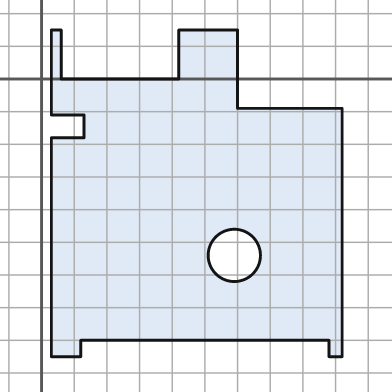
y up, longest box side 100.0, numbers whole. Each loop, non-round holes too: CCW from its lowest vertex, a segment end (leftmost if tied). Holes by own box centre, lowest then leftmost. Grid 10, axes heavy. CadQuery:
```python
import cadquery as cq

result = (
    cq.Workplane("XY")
    .moveTo(3.0, -85.0)
    .lineTo(12.0, -85.0)
    .lineTo(12.0, -80.0)
    .lineTo(88.0, -80.0)
    .lineTo(88.0, -85.0)
    .lineTo(92.0, -85.0)
    .lineTo(92.0, -9.0)
    .lineTo(60.0, -9.0)
    .lineTo(60.0, 15.0)
    .lineTo(42.0, 15.0)
    .lineTo(42.0, 0.0)
    .lineTo(6.0, 0.0)
    .lineTo(6.0, 15.0)
    .lineTo(3.0, 15.0)
    .lineTo(3.0, -11.0)
    .lineTo(13.0, -11.0)
    .lineTo(13.0, -18.0)
    .lineTo(3.0, -18.0)
    .close()
    .moveTo(59.0, -54.0)
    .circle(8.0)
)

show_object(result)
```